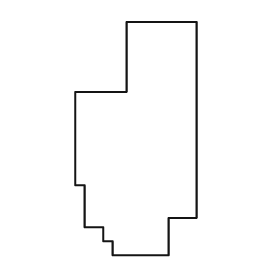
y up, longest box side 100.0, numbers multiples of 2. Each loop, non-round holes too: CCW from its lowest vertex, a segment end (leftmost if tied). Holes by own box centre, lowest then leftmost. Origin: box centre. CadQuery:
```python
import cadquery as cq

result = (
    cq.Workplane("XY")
    .moveTo(-10.0, -50.0)
    .lineTo(14.0, -50.0)
    .lineTo(14.0, -34.0)
    .lineTo(26.0, -34.0)
    .lineTo(26.0, 50.0)
    .lineTo(-4.0, 50.0)
    .lineTo(-4.0, 20.0)
    .lineTo(-26.0, 20.0)
    .lineTo(-26.0, -20.0)
    .lineTo(-22.0, -20.0)
    .lineTo(-22.0, -38.0)
    .lineTo(-14.0, -38.0)
    .lineTo(-14.0, -44.0)
    .lineTo(-10.0, -44.0)
    .close()
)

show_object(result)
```